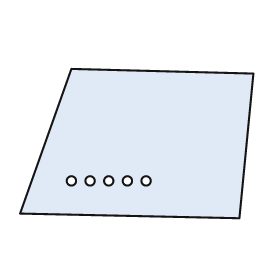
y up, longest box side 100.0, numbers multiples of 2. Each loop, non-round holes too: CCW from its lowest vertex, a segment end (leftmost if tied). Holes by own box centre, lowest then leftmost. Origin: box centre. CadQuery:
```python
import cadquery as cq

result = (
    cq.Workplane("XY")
    .moveTo(44.0, -32.0)
    .lineTo(50.0, 30.0)
    .lineTo(-28.0, 32.0)
    .lineTo(-50.0, -30.0)
    .close()
    .moveTo(-28.0, -16.0)
    .circle(2.0)
    .moveTo(-20.0, -16.0)
    .circle(2.0)
    .moveTo(-12.0, -16.0)
    .circle(2.0)
    .moveTo(-4.0, -16.0)
    .circle(2.0)
    .moveTo(4.0, -16.0)
    .circle(2.0)
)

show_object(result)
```